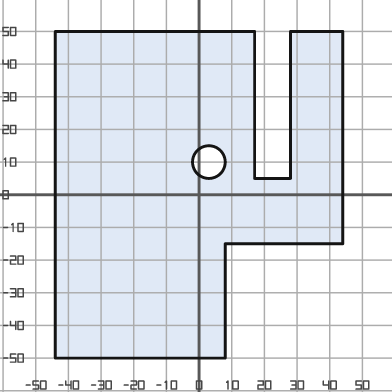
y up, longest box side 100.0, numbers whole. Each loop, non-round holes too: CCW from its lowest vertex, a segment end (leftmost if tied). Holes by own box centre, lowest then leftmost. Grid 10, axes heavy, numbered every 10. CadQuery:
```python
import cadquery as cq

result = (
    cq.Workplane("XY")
    .moveTo(-44.0, -50.0)
    .lineTo(8.0, -50.0)
    .lineTo(8.0, -15.0)
    .lineTo(44.0, -15.0)
    .lineTo(44.0, 50.0)
    .lineTo(28.0, 50.0)
    .lineTo(28.0, 5.0)
    .lineTo(17.0, 5.0)
    .lineTo(17.0, 50.0)
    .lineTo(-44.0, 50.0)
    .close()
    .moveTo(3.0, 10.0)
    .circle(5.0)
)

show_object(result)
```